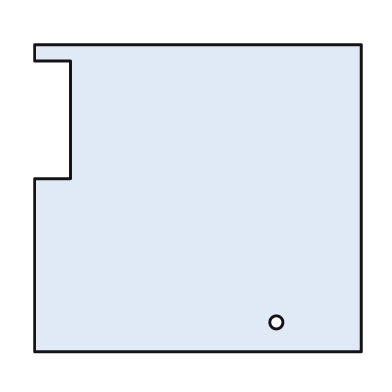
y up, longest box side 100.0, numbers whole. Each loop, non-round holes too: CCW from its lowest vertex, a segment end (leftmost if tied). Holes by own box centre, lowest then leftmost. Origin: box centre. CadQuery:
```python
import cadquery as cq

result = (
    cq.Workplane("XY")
    .moveTo(-50.0, -47.0)
    .lineTo(50.0, -47.0)
    .lineTo(50.0, 47.0)
    .lineTo(-50.0, 47.0)
    .lineTo(-50.0, 42.0)
    .lineTo(-39.0, 42.0)
    .lineTo(-39.0, 6.0)
    .lineTo(-50.0, 6.0)
    .close()
    .moveTo(24.0, -38.0)
    .circle(2.0)
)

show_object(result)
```